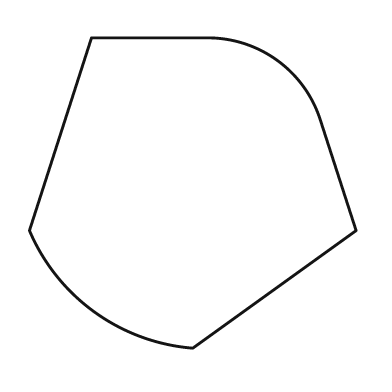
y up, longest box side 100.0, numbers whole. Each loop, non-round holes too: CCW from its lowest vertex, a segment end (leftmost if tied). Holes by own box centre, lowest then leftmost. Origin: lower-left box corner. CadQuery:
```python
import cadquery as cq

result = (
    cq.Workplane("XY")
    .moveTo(50.0, 0.0)
    .lineTo(100.0, 36.0)
    .lineTo(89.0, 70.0)
    .threePointArc((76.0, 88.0), (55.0, 95.0))
    .lineTo(19.0, 95.0)
    .lineTo(0.0, 36.0)
    .threePointArc((20.0, 11.0), (50.0, 0.0))
    .close()
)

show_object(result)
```